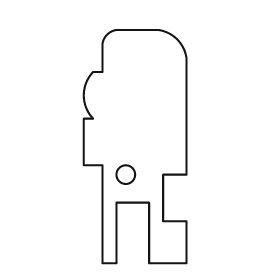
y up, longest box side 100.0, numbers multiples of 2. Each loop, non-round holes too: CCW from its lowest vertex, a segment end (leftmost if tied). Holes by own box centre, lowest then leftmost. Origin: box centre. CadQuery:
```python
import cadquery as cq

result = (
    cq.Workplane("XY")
    .moveTo(-14.0, -50.0)
    .lineTo(-8.0, -50.0)
    .lineTo(-8.0, -24.0)
    .lineTo(6.0, -24.0)
    .lineTo(6.0, -50.0)
    .lineTo(22.0, -50.0)
    .lineTo(22.0, -32.0)
    .lineTo(12.0, -32.0)
    .lineTo(12.0, -12.0)
    .lineTo(22.0, -12.0)
    .lineTo(22.0, 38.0)
    .threePointArc((18.0, 46.0), (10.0, 50.0))
    .lineTo(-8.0, 50.0)
    .threePointArc((-12.0, 48.0), (-14.0, 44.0))
    .lineTo(-14.0, 32.0)
    .lineTo(-18.0, 32.0)
    .threePointArc((-22.0, 22.0), (-18.0, 12.0))
    .lineTo(-22.0, 12.0)
    .lineTo(-22.0, -8.0)
    .lineTo(-14.0, -8.0)
    .close()
    .moveTo(-4.0, -12.0)
    .circle(4.0)
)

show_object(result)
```